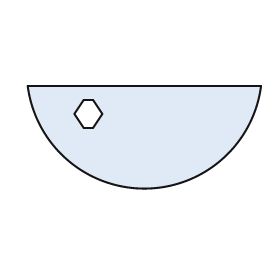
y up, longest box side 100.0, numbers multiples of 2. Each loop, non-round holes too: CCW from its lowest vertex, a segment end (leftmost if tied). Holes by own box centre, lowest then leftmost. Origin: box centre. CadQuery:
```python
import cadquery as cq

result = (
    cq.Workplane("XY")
    .moveTo(-50.0, 22.0)
    .threePointArc((0.0, -22.0), (50.0, 22.0))
    .close()
    .moveTo(-26.0, 4.0)
    .lineTo(-22.0, 4.0)
    .lineTo(-18.0, 10.0)
    .lineTo(-22.0, 16.0)
    .lineTo(-26.0, 16.0)
    .lineTo(-30.0, 10.0)
    .close()
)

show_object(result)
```